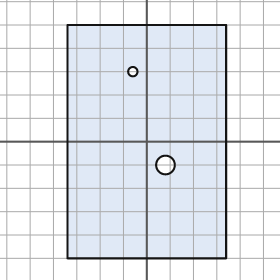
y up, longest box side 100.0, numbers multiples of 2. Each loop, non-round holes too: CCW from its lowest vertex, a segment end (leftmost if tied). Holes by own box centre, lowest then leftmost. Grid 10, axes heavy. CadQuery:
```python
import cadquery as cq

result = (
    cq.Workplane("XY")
    .moveTo(-34.0, -50.0)
    .lineTo(34.0, -50.0)
    .lineTo(34.0, 50.0)
    .lineTo(-34.0, 50.0)
    .close()
    .moveTo(8.0, -10.0)
    .circle(4.0)
    .moveTo(-6.0, 30.0)
    .circle(2.0)
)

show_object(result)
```